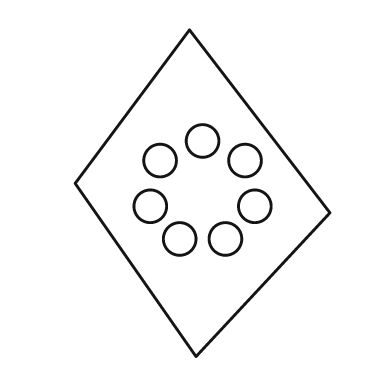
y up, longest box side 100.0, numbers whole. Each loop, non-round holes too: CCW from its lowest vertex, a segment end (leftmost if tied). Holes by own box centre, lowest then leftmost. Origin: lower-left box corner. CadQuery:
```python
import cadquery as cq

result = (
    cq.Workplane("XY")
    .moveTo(37.0, 0.0)
    .lineTo(78.0, 44.0)
    .lineTo(35.0, 100.0)
    .lineTo(0.0, 53.0)
    .close()
    .moveTo(32.0, 36.0)
    .circle(5.0)
    .moveTo(46.0, 36.0)
    .circle(5.0)
    .moveTo(23.0, 46.0)
    .circle(5.0)
    .moveTo(55.0, 46.0)
    .circle(5.0)
    .moveTo(26.0, 60.0)
    .circle(5.0)
    .moveTo(52.0, 60.0)
    .circle(5.0)
    .moveTo(39.0, 66.0)
    .circle(5.0)
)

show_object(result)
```